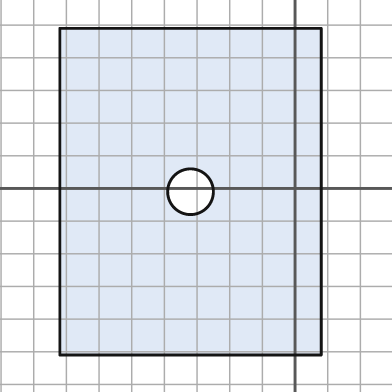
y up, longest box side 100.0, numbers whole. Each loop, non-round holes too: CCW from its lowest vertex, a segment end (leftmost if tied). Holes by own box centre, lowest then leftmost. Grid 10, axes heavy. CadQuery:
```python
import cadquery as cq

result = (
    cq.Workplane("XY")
    .moveTo(-72.0, -51.0)
    .lineTo(8.0, -51.0)
    .lineTo(8.0, 49.0)
    .lineTo(-72.0, 49.0)
    .close()
    .moveTo(-32.0, -1.0)
    .circle(7.0)
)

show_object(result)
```